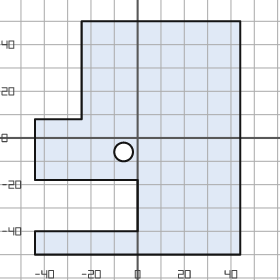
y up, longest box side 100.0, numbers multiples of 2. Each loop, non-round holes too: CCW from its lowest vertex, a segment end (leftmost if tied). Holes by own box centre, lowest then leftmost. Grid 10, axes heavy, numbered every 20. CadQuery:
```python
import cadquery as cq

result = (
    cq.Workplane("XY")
    .moveTo(-44.0, -50.0)
    .lineTo(44.0, -50.0)
    .lineTo(44.0, 50.0)
    .lineTo(-24.0, 50.0)
    .lineTo(-24.0, 8.0)
    .lineTo(-44.0, 8.0)
    .lineTo(-44.0, -18.0)
    .lineTo(0.0, -18.0)
    .lineTo(0.0, -40.0)
    .lineTo(-44.0, -40.0)
    .close()
    .moveTo(-6.0, -6.0)
    .circle(4.0)
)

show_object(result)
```